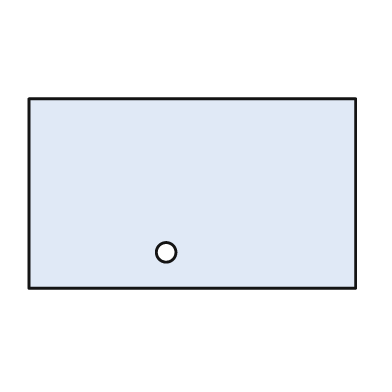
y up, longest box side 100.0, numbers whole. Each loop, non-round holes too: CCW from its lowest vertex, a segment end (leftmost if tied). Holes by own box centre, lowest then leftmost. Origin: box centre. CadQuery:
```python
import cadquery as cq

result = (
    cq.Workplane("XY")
    .moveTo(-50.0, -29.0)
    .lineTo(50.0, -29.0)
    .lineTo(50.0, 29.0)
    .lineTo(-50.0, 29.0)
    .close()
    .moveTo(-8.0, -18.0)
    .circle(3.0)
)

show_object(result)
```